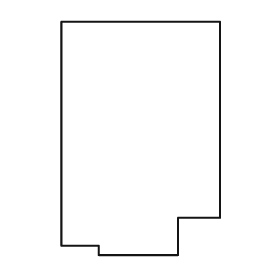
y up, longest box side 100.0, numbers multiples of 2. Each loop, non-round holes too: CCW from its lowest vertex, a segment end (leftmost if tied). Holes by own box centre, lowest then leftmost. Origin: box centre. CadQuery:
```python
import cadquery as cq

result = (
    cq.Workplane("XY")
    .moveTo(-18.0, -50.0)
    .lineTo(16.0, -50.0)
    .lineTo(16.0, -34.0)
    .lineTo(34.0, -34.0)
    .lineTo(34.0, 50.0)
    .lineTo(-34.0, 50.0)
    .lineTo(-34.0, -46.0)
    .lineTo(-18.0, -46.0)
    .close()
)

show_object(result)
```